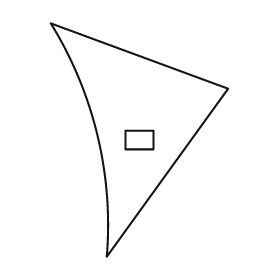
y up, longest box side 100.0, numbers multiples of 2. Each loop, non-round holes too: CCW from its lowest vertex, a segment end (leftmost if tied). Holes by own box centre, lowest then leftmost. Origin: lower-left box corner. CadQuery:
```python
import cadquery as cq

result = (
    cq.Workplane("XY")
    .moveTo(24.0, 0.0)
    .lineTo(76.0, 72.0)
    .lineTo(0.0, 100.0)
    .threePointArc((20.0, 52.0), (24.0, 0.0))
    .close()
    .moveTo(32.0, 46.0)
    .lineTo(44.0, 46.0)
    .lineTo(44.0, 54.0)
    .lineTo(32.0, 54.0)
    .close()
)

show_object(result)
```